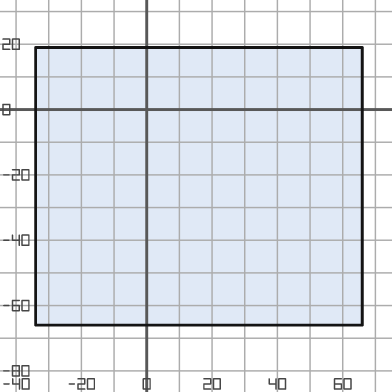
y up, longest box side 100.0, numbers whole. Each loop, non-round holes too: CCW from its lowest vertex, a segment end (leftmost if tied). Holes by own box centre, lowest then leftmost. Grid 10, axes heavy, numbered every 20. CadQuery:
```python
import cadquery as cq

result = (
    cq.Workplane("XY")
    .moveTo(-34.0, -66.0)
    .lineTo(66.0, -66.0)
    .lineTo(66.0, 19.0)
    .lineTo(-34.0, 19.0)
    .close()
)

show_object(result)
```